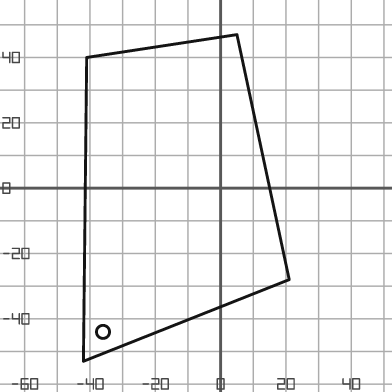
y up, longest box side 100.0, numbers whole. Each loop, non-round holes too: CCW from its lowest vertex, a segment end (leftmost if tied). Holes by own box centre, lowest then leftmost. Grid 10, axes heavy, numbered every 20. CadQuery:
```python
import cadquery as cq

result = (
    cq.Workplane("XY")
    .moveTo(-42.0, -53.0)
    .lineTo(21.0, -28.0)
    .lineTo(5.0, 47.0)
    .lineTo(-41.0, 40.0)
    .close()
    .moveTo(-36.0, -44.0)
    .circle(2.0)
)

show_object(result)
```